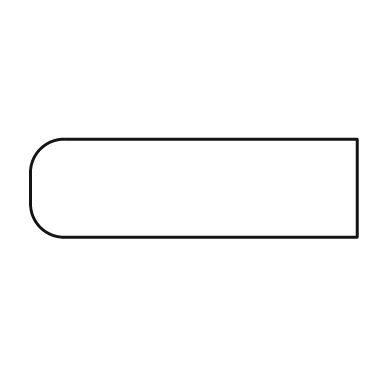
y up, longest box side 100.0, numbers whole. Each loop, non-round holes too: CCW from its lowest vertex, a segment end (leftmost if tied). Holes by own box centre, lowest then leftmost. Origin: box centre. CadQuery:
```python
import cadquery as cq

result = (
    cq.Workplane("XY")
    .moveTo(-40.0, -15.0)
    .lineTo(50.0, -15.0)
    .lineTo(50.0, 15.0)
    .lineTo(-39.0, 15.0)
    .threePointArc((-47.0, 12.0), (-50.0, 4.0))
    .lineTo(-50.0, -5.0)
    .threePointArc((-47.0, -12.0), (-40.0, -15.0))
    .close()
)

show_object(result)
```